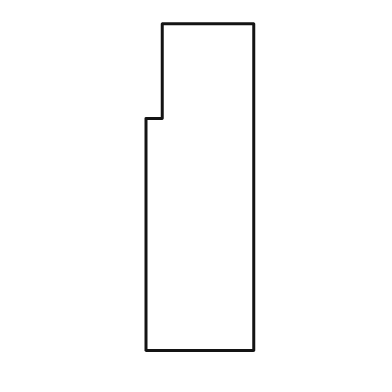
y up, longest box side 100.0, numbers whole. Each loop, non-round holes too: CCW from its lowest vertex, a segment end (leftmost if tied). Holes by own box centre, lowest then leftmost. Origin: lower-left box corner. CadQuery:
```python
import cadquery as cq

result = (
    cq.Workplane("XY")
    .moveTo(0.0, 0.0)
    .lineTo(33.0, 0.0)
    .lineTo(33.0, 100.0)
    .lineTo(5.0, 100.0)
    .lineTo(5.0, 71.0)
    .lineTo(0.0, 71.0)
    .close()
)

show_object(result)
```